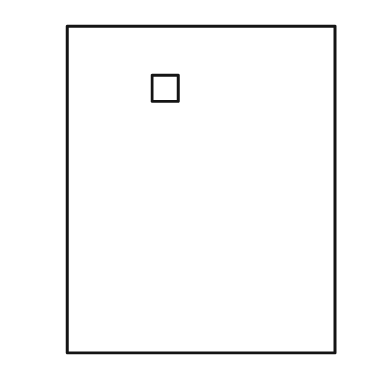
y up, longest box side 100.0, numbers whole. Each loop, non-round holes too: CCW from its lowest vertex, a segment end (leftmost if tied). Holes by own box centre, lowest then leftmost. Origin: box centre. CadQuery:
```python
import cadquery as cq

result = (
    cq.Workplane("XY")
    .moveTo(-41.0, -50.0)
    .lineTo(41.0, -50.0)
    .lineTo(41.0, 50.0)
    .lineTo(-41.0, 50.0)
    .close()
    .moveTo(-15.0, 27.0)
    .lineTo(-7.0, 27.0)
    .lineTo(-7.0, 35.0)
    .lineTo(-15.0, 35.0)
    .close()
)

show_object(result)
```